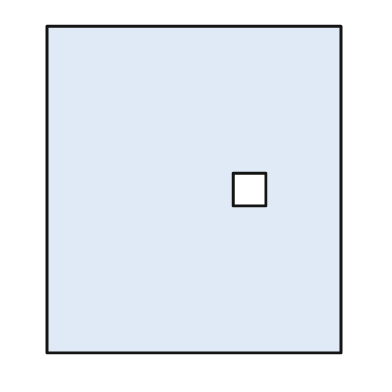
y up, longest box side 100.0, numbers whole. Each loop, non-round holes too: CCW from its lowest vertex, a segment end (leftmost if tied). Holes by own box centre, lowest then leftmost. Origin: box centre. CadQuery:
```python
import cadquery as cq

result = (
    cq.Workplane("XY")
    .moveTo(-45.0, -50.0)
    .lineTo(45.0, -50.0)
    .lineTo(45.0, 50.0)
    .lineTo(-45.0, 50.0)
    .close()
    .moveTo(12.0, -5.0)
    .lineTo(22.0, -5.0)
    .lineTo(22.0, 5.0)
    .lineTo(12.0, 5.0)
    .close()
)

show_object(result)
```